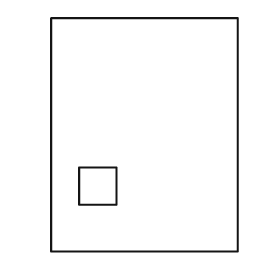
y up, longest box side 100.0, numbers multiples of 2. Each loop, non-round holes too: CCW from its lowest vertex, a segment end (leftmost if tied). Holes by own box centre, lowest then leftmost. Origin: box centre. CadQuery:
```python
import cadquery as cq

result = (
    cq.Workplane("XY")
    .moveTo(-40.0, -50.0)
    .lineTo(40.0, -50.0)
    .lineTo(40.0, 50.0)
    .lineTo(-40.0, 50.0)
    .close()
    .moveTo(-28.0, -30.0)
    .lineTo(-12.0, -30.0)
    .lineTo(-12.0, -14.0)
    .lineTo(-28.0, -14.0)
    .close()
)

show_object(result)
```